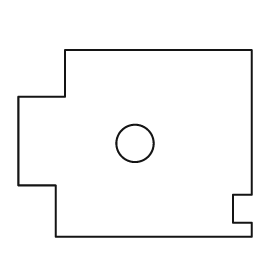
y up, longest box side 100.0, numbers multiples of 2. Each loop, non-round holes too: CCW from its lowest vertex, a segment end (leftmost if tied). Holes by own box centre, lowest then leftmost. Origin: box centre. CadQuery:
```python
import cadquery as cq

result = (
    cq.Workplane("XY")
    .moveTo(-34.0, -40.0)
    .lineTo(50.0, -40.0)
    .lineTo(50.0, -34.0)
    .lineTo(42.0, -34.0)
    .lineTo(42.0, -22.0)
    .lineTo(50.0, -22.0)
    .lineTo(50.0, 40.0)
    .lineTo(-30.0, 40.0)
    .lineTo(-30.0, 20.0)
    .lineTo(-50.0, 20.0)
    .lineTo(-50.0, -18.0)
    .lineTo(-34.0, -18.0)
    .close()
    .moveTo(0.0, 0.0)
    .circle(8.0)
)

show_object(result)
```